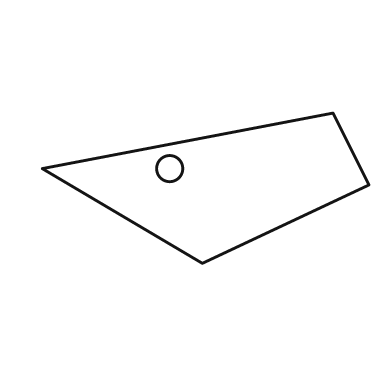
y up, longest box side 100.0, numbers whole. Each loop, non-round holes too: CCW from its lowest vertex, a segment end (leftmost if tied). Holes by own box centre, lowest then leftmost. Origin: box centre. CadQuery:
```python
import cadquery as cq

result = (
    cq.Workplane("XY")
    .moveTo(-1.0, -23.0)
    .lineTo(50.0, 1.0)
    .lineTo(39.0, 23.0)
    .lineTo(-50.0, 6.0)
    .close()
    .moveTo(-11.0, 6.0)
    .circle(4.0)
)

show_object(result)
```